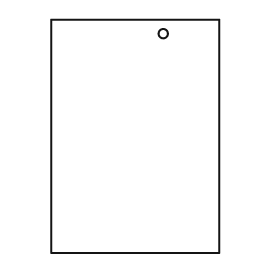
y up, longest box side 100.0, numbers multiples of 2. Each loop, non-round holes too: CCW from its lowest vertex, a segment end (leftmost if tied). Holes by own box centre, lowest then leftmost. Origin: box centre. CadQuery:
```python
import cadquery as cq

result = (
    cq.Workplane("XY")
    .moveTo(-36.0, -50.0)
    .lineTo(36.0, -50.0)
    .lineTo(36.0, 50.0)
    .lineTo(-36.0, 50.0)
    .close()
    .moveTo(12.0, 44.0)
    .circle(2.0)
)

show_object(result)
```